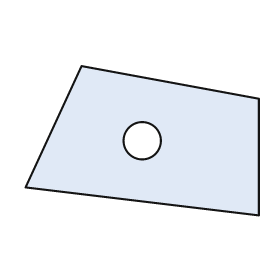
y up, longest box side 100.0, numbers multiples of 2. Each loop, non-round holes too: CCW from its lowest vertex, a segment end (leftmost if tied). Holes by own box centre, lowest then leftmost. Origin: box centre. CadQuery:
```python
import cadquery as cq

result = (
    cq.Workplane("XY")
    .moveTo(50.0, -32.0)
    .lineTo(50.0, 18.0)
    .lineTo(-26.0, 32.0)
    .lineTo(-50.0, -20.0)
    .close()
    .moveTo(0.0, 0.0)
    .circle(8.0)
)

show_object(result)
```